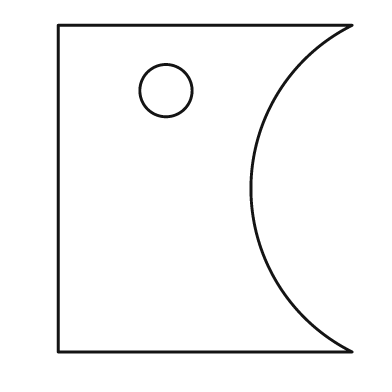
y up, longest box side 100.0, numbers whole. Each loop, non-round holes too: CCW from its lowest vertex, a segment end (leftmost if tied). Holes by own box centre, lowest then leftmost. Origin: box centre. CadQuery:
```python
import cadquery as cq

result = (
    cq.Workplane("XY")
    .moveTo(-45.0, -50.0)
    .lineTo(45.0, -50.0)
    .threePointArc((14.0, 0.0), (45.0, 50.0))
    .lineTo(-45.0, 50.0)
    .close()
    .moveTo(-12.0, 30.0)
    .circle(8.0)
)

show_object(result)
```